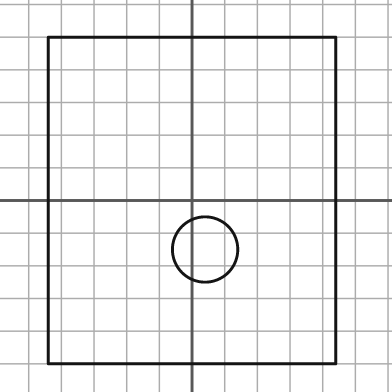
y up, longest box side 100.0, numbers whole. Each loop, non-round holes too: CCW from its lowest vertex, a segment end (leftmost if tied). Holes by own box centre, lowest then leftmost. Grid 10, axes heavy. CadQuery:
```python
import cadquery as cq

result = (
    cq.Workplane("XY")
    .moveTo(-44.0, -50.0)
    .lineTo(44.0, -50.0)
    .lineTo(44.0, 50.0)
    .lineTo(-44.0, 50.0)
    .close()
    .moveTo(4.0, -15.0)
    .circle(10.0)
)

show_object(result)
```